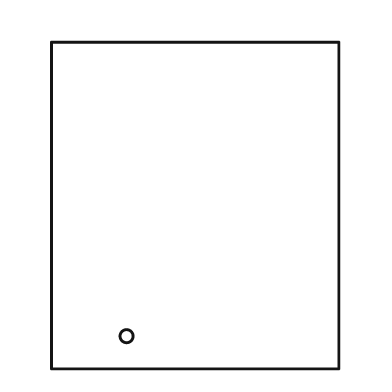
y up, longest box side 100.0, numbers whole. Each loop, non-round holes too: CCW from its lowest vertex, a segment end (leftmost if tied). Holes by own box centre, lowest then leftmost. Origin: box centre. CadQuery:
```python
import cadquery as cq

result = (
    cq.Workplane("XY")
    .moveTo(-44.0, -50.0)
    .lineTo(44.0, -50.0)
    .lineTo(44.0, 50.0)
    .lineTo(-44.0, 50.0)
    .close()
    .moveTo(-21.0, -40.0)
    .circle(2.0)
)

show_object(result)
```